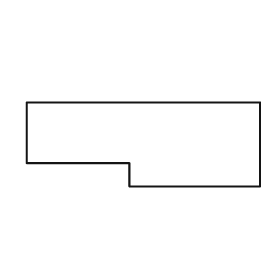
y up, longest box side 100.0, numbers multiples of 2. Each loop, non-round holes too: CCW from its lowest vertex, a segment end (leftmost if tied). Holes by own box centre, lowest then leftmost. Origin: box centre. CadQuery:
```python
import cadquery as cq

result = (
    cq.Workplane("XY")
    .moveTo(-6.0, -18.0)
    .lineTo(50.0, -18.0)
    .lineTo(50.0, 18.0)
    .lineTo(-50.0, 18.0)
    .lineTo(-50.0, -8.0)
    .lineTo(-6.0, -8.0)
    .close()
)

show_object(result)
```